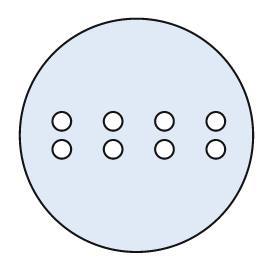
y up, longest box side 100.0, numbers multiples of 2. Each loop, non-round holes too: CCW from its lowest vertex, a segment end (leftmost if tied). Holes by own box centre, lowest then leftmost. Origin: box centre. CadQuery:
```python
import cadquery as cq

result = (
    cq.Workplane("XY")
    .moveTo(0.0, 0.0)
    .circle(50.0)
    .moveTo(-32.0, -6.0)
    .circle(4.0)
    .moveTo(-10.0, -6.0)
    .circle(4.0)
    .moveTo(12.0, -6.0)
    .circle(4.0)
    .moveTo(34.0, -6.0)
    .circle(4.0)
    .moveTo(-32.0, 6.0)
    .circle(4.0)
    .moveTo(-10.0, 6.0)
    .circle(4.0)
    .moveTo(12.0, 6.0)
    .circle(4.0)
    .moveTo(34.0, 6.0)
    .circle(4.0)
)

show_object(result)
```